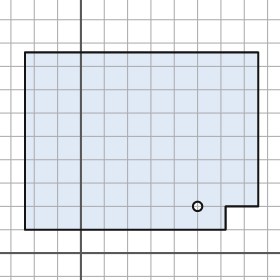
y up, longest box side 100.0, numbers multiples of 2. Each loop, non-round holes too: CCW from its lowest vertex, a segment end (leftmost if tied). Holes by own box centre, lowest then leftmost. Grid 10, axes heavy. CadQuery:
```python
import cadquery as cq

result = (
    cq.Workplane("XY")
    .moveTo(-24.0, 10.0)
    .lineTo(62.0, 10.0)
    .lineTo(62.0, 20.0)
    .lineTo(76.0, 20.0)
    .lineTo(76.0, 86.0)
    .lineTo(-24.0, 86.0)
    .close()
    .moveTo(50.0, 20.0)
    .circle(2.0)
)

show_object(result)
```